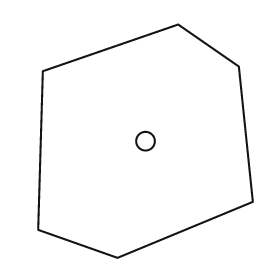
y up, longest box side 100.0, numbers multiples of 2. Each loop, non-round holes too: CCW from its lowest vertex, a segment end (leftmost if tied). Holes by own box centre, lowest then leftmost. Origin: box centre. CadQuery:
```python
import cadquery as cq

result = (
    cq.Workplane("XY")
    .moveTo(-12.0, -50.0)
    .lineTo(46.0, -26.0)
    .lineTo(40.0, 32.0)
    .lineTo(14.0, 50.0)
    .lineTo(-44.0, 30.0)
    .lineTo(-46.0, -38.0)
    .close()
    .moveTo(0.0, 0.0)
    .circle(4.0)
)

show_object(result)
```